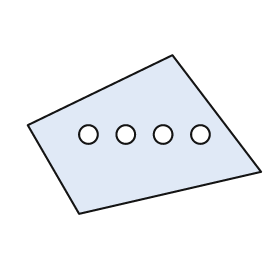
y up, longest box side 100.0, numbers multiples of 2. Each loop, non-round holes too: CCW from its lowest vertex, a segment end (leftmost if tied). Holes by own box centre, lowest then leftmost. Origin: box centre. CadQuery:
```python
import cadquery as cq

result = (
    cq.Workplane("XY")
    .moveTo(-28.0, -34.0)
    .lineTo(50.0, -16.0)
    .lineTo(12.0, 34.0)
    .lineTo(-50.0, 4.0)
    .close()
    .moveTo(-24.0, 0.0)
    .circle(4.0)
    .moveTo(-8.0, 0.0)
    .circle(4.0)
    .moveTo(8.0, 0.0)
    .circle(4.0)
    .moveTo(24.0, 0.0)
    .circle(4.0)
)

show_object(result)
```